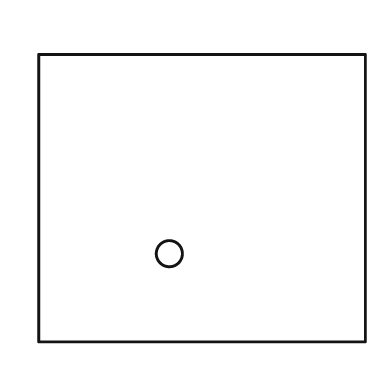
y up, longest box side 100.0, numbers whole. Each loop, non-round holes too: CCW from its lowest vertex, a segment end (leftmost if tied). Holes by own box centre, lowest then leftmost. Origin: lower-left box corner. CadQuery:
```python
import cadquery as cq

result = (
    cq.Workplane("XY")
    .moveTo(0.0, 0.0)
    .lineTo(100.0, 0.0)
    .lineTo(100.0, 88.0)
    .lineTo(0.0, 88.0)
    .close()
    .moveTo(40.0, 27.0)
    .circle(4.0)
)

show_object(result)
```